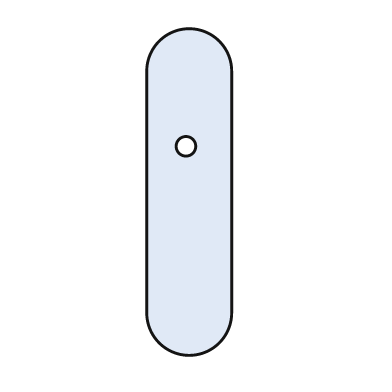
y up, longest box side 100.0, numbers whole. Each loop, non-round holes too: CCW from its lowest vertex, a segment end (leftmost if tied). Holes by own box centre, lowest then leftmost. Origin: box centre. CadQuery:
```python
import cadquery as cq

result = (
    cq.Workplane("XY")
    .moveTo(-13.0, -37.0)
    .threePointArc((0.0, -50.0), (13.0, -37.0))
    .lineTo(13.0, 37.0)
    .threePointArc((0.0, 50.0), (-13.0, 37.0))
    .close()
    .moveTo(-1.0, 14.0)
    .circle(3.0)
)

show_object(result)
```